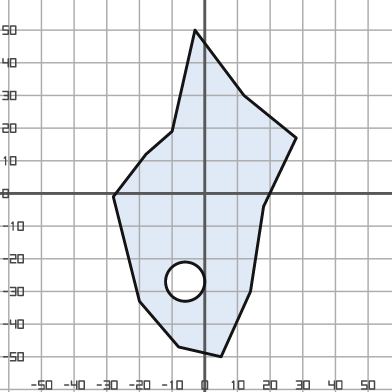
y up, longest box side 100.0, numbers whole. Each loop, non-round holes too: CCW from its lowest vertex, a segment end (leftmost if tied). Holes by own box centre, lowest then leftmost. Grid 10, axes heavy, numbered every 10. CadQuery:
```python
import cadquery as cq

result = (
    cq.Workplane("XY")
    .moveTo(5.0, -50.0)
    .lineTo(14.0, -30.0)
    .lineTo(18.0, -4.0)
    .lineTo(28.0, 17.0)
    .lineTo(12.0, 30.0)
    .lineTo(-3.0, 50.0)
    .lineTo(-10.0, 19.0)
    .lineTo(-18.0, 12.0)
    .lineTo(-28.0, -1.0)
    .lineTo(-20.0, -33.0)
    .lineTo(-8.0, -47.0)
    .close()
    .moveTo(-6.0, -27.0)
    .circle(6.0)
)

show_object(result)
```